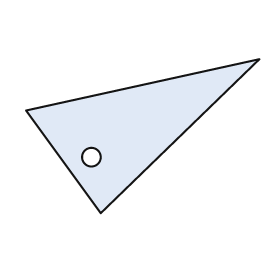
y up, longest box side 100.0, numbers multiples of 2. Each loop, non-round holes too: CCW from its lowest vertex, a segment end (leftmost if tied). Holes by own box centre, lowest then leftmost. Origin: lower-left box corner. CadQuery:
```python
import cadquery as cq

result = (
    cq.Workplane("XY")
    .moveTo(32.0, 0.0)
    .lineTo(100.0, 66.0)
    .lineTo(0.0, 44.0)
    .close()
    .moveTo(28.0, 24.0)
    .circle(4.0)
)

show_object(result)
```